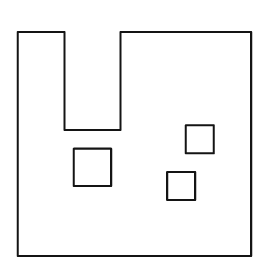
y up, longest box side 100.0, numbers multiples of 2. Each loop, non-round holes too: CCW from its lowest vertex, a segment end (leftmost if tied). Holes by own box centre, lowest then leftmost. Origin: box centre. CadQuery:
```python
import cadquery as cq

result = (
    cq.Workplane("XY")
    .moveTo(-50.0, -48.0)
    .lineTo(50.0, -48.0)
    .lineTo(50.0, 48.0)
    .lineTo(-6.0, 48.0)
    .lineTo(-6.0, 6.0)
    .lineTo(-30.0, 6.0)
    .lineTo(-30.0, 48.0)
    .lineTo(-50.0, 48.0)
    .close()
    .moveTo(14.0, -24.0)
    .lineTo(26.0, -24.0)
    .lineTo(26.0, -12.0)
    .lineTo(14.0, -12.0)
    .close()
    .moveTo(-26.0, -18.0)
    .lineTo(-10.0, -18.0)
    .lineTo(-10.0, -2.0)
    .lineTo(-26.0, -2.0)
    .close()
    .moveTo(22.0, -4.0)
    .lineTo(34.0, -4.0)
    .lineTo(34.0, 8.0)
    .lineTo(22.0, 8.0)
    .close()
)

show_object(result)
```